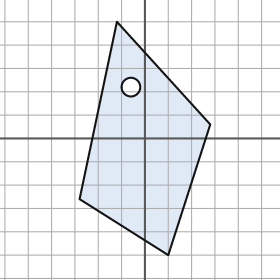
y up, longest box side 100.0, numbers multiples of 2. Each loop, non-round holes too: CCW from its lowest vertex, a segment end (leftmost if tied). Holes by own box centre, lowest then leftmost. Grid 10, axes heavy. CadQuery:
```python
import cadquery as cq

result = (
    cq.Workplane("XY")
    .moveTo(10.0, -50.0)
    .lineTo(28.0, 6.0)
    .lineTo(-12.0, 50.0)
    .lineTo(-28.0, -26.0)
    .close()
    .moveTo(-6.0, 22.0)
    .circle(4.0)
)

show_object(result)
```